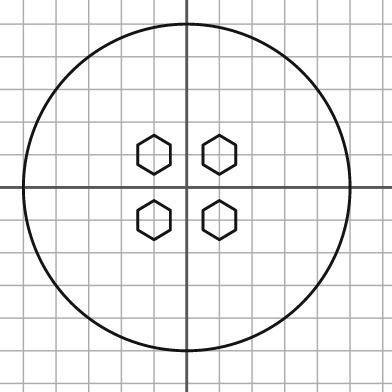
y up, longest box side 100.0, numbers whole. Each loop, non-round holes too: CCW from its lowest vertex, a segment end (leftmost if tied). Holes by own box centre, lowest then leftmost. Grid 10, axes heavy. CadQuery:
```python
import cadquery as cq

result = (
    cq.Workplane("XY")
    .moveTo(0.0, 0.0)
    .circle(50.0)
    .moveTo(-10.0, -16.0)
    .lineTo(-5.0, -13.0)
    .lineTo(-5.0, -7.0)
    .lineTo(-10.0, -4.0)
    .lineTo(-15.0, -7.0)
    .lineTo(-15.0, -13.0)
    .close()
    .moveTo(10.0, -16.0)
    .lineTo(15.0, -13.0)
    .lineTo(15.0, -7.0)
    .lineTo(10.0, -4.0)
    .lineTo(5.0, -7.0)
    .lineTo(5.0, -13.0)
    .close()
    .moveTo(-10.0, 4.0)
    .lineTo(-5.0, 7.0)
    .lineTo(-5.0, 13.0)
    .lineTo(-10.0, 16.0)
    .lineTo(-15.0, 13.0)
    .lineTo(-15.0, 7.0)
    .close()
    .moveTo(10.0, 4.0)
    .lineTo(15.0, 7.0)
    .lineTo(15.0, 13.0)
    .lineTo(10.0, 16.0)
    .lineTo(5.0, 13.0)
    .lineTo(5.0, 7.0)
    .close()
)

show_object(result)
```